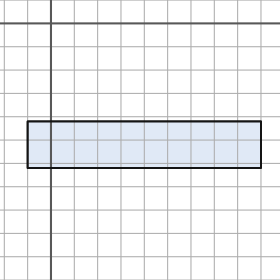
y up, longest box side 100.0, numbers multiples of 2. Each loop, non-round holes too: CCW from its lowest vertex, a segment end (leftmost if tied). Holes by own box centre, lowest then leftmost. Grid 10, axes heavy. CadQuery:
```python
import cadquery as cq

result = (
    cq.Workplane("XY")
    .moveTo(-10.0, -62.0)
    .lineTo(90.0, -62.0)
    .lineTo(90.0, -42.0)
    .lineTo(-10.0, -42.0)
    .close()
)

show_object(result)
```